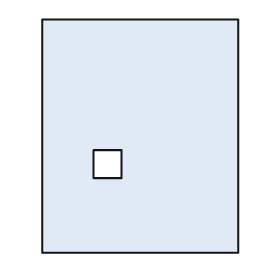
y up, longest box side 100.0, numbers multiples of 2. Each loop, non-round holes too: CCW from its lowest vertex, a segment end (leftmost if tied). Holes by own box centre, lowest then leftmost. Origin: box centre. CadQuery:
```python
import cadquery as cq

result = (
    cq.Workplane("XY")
    .moveTo(-42.0, -50.0)
    .lineTo(42.0, -50.0)
    .lineTo(42.0, 50.0)
    .lineTo(-42.0, 50.0)
    .close()
    .moveTo(-20.0, -18.0)
    .lineTo(-8.0, -18.0)
    .lineTo(-8.0, -6.0)
    .lineTo(-20.0, -6.0)
    .close()
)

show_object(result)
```